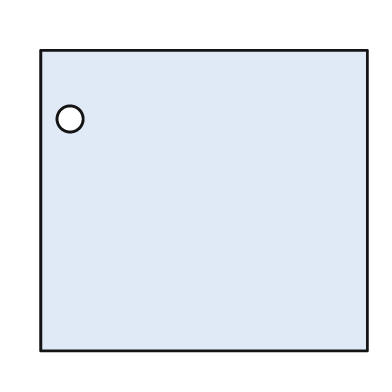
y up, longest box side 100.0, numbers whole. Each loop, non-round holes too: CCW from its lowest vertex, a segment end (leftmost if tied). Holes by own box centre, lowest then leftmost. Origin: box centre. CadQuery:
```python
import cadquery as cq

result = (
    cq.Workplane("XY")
    .moveTo(-50.0, -46.0)
    .lineTo(50.0, -46.0)
    .lineTo(50.0, 46.0)
    .lineTo(-50.0, 46.0)
    .close()
    .moveTo(-41.0, 25.0)
    .circle(4.0)
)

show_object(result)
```